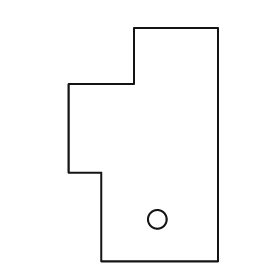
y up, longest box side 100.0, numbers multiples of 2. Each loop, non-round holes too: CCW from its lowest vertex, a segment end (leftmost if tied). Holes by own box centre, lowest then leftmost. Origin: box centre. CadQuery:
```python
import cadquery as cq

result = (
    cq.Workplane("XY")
    .moveTo(-18.0, -50.0)
    .lineTo(32.0, -50.0)
    .lineTo(32.0, 50.0)
    .lineTo(-4.0, 50.0)
    .lineTo(-4.0, 26.0)
    .lineTo(-32.0, 26.0)
    .lineTo(-32.0, -12.0)
    .lineTo(-18.0, -12.0)
    .close()
    .moveTo(6.0, -32.0)
    .circle(4.0)
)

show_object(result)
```